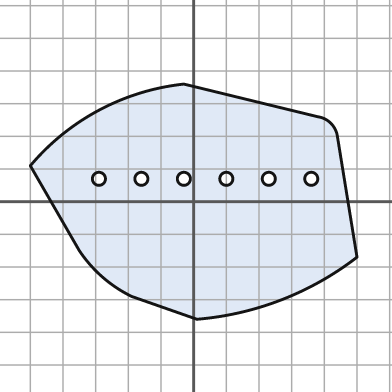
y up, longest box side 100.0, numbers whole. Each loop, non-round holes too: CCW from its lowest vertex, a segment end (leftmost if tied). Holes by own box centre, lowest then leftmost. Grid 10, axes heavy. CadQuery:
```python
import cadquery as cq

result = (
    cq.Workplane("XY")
    .moveTo(1.0, -36.0)
    .threePointArc((27.0, -30.0), (50.0, -17.0))
    .lineTo(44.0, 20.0)
    .threePointArc((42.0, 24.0), (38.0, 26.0))
    .lineTo(-3.0, 36.0)
    .threePointArc((-29.0, 28.0), (-50.0, 11.0))
    .lineTo(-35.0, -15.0)
    .threePointArc((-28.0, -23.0), (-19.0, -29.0))
    .close()
    .moveTo(-29.0, 7.0)
    .circle(2.0)
    .moveTo(-16.0, 7.0)
    .circle(2.0)
    .moveTo(-3.0, 7.0)
    .circle(2.0)
    .moveTo(10.0, 7.0)
    .circle(2.0)
    .moveTo(23.0, 7.0)
    .circle(2.0)
    .moveTo(36.0, 7.0)
    .circle(2.0)
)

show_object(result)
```